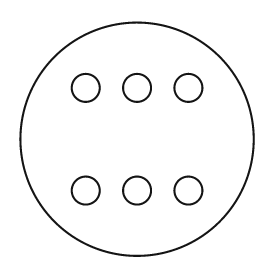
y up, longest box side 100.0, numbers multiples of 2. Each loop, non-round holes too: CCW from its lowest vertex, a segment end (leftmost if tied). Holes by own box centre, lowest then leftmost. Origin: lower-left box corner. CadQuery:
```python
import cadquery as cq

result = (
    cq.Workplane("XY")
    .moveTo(50.0, 50.0)
    .circle(50.0)
    .moveTo(28.0, 28.0)
    .circle(6.0)
    .moveTo(50.0, 28.0)
    .circle(6.0)
    .moveTo(72.0, 28.0)
    .circle(6.0)
    .moveTo(28.0, 72.0)
    .circle(6.0)
    .moveTo(50.0, 72.0)
    .circle(6.0)
    .moveTo(72.0, 72.0)
    .circle(6.0)
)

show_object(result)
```